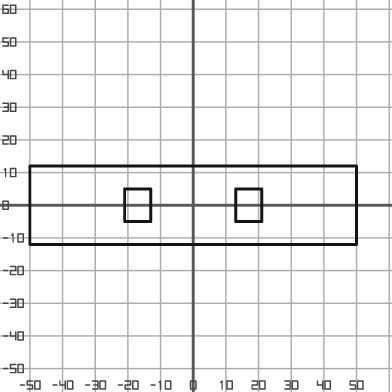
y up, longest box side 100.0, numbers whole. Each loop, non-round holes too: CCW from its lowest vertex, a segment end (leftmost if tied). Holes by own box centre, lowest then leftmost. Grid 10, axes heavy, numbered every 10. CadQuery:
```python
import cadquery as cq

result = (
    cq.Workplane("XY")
    .moveTo(-50.0, -12.0)
    .lineTo(50.0, -12.0)
    .lineTo(50.0, 12.0)
    .lineTo(-50.0, 12.0)
    .close()
    .moveTo(-21.0, -5.0)
    .lineTo(-13.0, -5.0)
    .lineTo(-13.0, 5.0)
    .lineTo(-21.0, 5.0)
    .close()
    .moveTo(13.0, -5.0)
    .lineTo(21.0, -5.0)
    .lineTo(21.0, 5.0)
    .lineTo(13.0, 5.0)
    .close()
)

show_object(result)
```